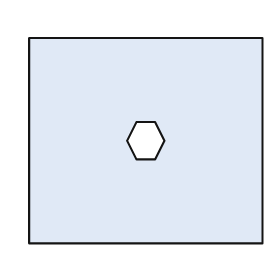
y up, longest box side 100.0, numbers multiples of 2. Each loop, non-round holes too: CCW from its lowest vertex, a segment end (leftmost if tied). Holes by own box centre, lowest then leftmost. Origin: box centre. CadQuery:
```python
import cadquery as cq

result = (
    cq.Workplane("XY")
    .moveTo(-50.0, -44.0)
    .lineTo(50.0, -44.0)
    .lineTo(50.0, 44.0)
    .lineTo(-50.0, 44.0)
    .close()
    .moveTo(-4.0, -8.0)
    .lineTo(4.0, -8.0)
    .lineTo(8.0, 0.0)
    .lineTo(4.0, 8.0)
    .lineTo(-4.0, 8.0)
    .lineTo(-8.0, 0.0)
    .close()
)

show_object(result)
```